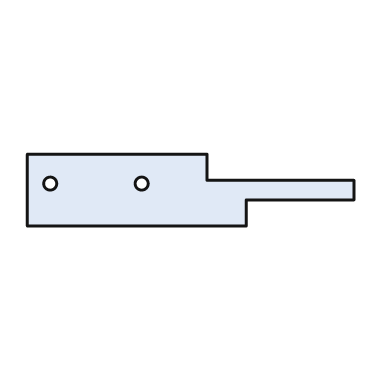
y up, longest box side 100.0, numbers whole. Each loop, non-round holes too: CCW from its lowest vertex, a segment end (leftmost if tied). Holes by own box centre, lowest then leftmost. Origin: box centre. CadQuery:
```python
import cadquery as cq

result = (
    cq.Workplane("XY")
    .moveTo(-50.0, -11.0)
    .lineTo(17.0, -11.0)
    .lineTo(17.0, -3.0)
    .lineTo(50.0, -3.0)
    .lineTo(50.0, 3.0)
    .lineTo(5.0, 3.0)
    .lineTo(5.0, 11.0)
    .lineTo(-50.0, 11.0)
    .close()
    .moveTo(-43.0, 2.0)
    .circle(2.0)
    .moveTo(-15.0, 2.0)
    .circle(2.0)
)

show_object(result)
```